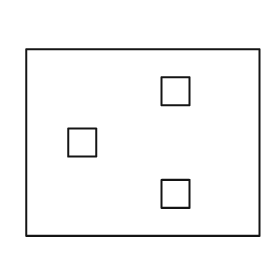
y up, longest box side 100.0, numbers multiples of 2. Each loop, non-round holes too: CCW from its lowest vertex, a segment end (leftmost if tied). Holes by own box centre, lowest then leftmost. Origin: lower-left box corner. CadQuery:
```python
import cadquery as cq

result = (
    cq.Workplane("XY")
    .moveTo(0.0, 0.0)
    .lineTo(100.0, 0.0)
    .lineTo(100.0, 80.0)
    .lineTo(0.0, 80.0)
    .close()
    .moveTo(58.0, 12.0)
    .lineTo(70.0, 12.0)
    .lineTo(70.0, 24.0)
    .lineTo(58.0, 24.0)
    .close()
    .moveTo(18.0, 34.0)
    .lineTo(30.0, 34.0)
    .lineTo(30.0, 46.0)
    .lineTo(18.0, 46.0)
    .close()
    .moveTo(58.0, 56.0)
    .lineTo(70.0, 56.0)
    .lineTo(70.0, 68.0)
    .lineTo(58.0, 68.0)
    .close()
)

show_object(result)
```